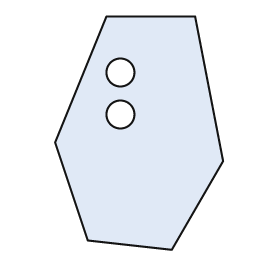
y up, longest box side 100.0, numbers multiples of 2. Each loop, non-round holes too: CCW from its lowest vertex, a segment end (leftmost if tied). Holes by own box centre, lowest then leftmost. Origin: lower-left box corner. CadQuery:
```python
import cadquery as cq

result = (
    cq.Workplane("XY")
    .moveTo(50.0, 0.0)
    .lineTo(72.0, 38.0)
    .lineTo(60.0, 100.0)
    .lineTo(22.0, 100.0)
    .lineTo(0.0, 46.0)
    .lineTo(14.0, 4.0)
    .close()
    .moveTo(28.0, 58.0)
    .circle(6.0)
    .moveTo(28.0, 76.0)
    .circle(6.0)
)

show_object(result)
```